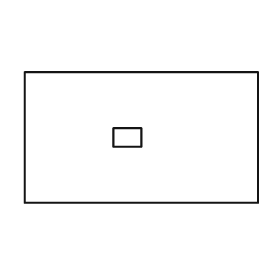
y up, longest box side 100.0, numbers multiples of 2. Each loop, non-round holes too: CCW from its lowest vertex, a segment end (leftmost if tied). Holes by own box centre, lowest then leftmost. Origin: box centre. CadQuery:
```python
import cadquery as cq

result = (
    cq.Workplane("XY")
    .moveTo(-50.0, -28.0)
    .lineTo(50.0, -28.0)
    .lineTo(50.0, 28.0)
    .lineTo(-50.0, 28.0)
    .close()
    .moveTo(-12.0, -4.0)
    .lineTo(0.0, -4.0)
    .lineTo(0.0, 4.0)
    .lineTo(-12.0, 4.0)
    .close()
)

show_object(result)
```